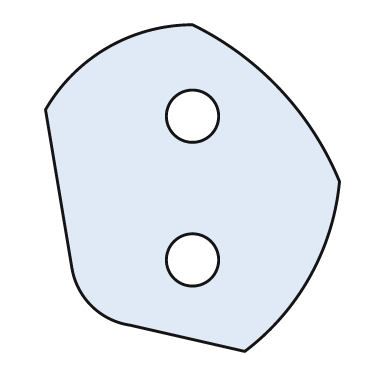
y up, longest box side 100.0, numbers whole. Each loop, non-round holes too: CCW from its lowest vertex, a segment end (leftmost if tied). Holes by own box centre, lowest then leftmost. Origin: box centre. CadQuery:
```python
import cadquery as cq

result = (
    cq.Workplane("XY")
    .moveTo(16.0, -50.0)
    .threePointArc((36.0, -27.0), (45.0, 2.0))
    .threePointArc((27.0, 30.0), (0.0, 50.0))
    .threePointArc((-26.0, 43.0), (-45.0, 24.0))
    .lineTo(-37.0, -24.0)
    .threePointArc((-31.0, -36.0), (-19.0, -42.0))
    .close()
    .moveTo(0.0, -22.0)
    .circle(8.0)
    .moveTo(0.0, 22.0)
    .circle(8.0)
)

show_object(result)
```